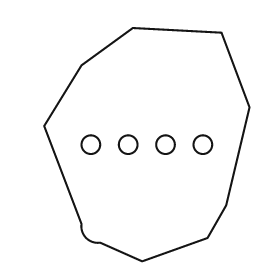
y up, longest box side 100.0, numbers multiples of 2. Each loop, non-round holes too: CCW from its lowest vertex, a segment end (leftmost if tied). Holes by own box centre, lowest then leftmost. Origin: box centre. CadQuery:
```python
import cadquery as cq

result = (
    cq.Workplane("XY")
    .moveTo(-2.0, -50.0)
    .lineTo(26.0, -40.0)
    .lineTo(34.0, -26.0)
    .lineTo(44.0, 16.0)
    .lineTo(32.0, 48.0)
    .lineTo(-6.0, 50.0)
    .lineTo(-28.0, 34.0)
    .lineTo(-44.0, 8.0)
    .lineTo(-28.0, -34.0)
    .threePointArc((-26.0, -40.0), (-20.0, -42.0))
    .close()
    .moveTo(-24.0, 0.0)
    .circle(4.0)
    .moveTo(-8.0, 0.0)
    .circle(4.0)
    .moveTo(8.0, 0.0)
    .circle(4.0)
    .moveTo(24.0, 0.0)
    .circle(4.0)
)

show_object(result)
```